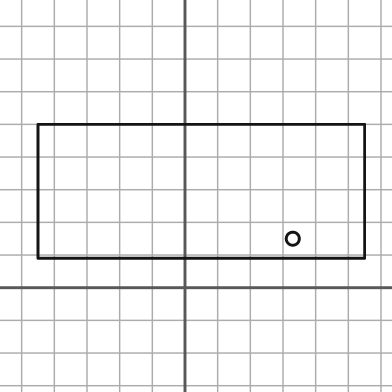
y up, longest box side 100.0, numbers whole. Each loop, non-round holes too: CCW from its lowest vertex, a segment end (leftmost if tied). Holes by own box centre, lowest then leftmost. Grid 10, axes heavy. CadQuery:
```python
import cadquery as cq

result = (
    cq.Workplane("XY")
    .moveTo(-45.0, 9.0)
    .lineTo(55.0, 9.0)
    .lineTo(55.0, 50.0)
    .lineTo(-45.0, 50.0)
    .close()
    .moveTo(33.0, 15.0)
    .circle(2.0)
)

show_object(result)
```